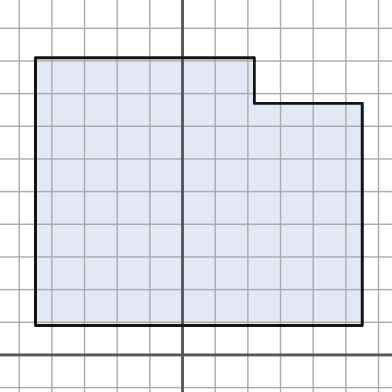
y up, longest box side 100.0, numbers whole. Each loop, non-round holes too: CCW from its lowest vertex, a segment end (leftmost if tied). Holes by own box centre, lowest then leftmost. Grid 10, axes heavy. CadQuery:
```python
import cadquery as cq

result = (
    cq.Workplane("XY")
    .moveTo(-45.0, 9.0)
    .lineTo(55.0, 9.0)
    .lineTo(55.0, 77.0)
    .lineTo(22.0, 77.0)
    .lineTo(22.0, 91.0)
    .lineTo(-45.0, 91.0)
    .close()
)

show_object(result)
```